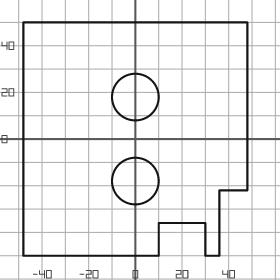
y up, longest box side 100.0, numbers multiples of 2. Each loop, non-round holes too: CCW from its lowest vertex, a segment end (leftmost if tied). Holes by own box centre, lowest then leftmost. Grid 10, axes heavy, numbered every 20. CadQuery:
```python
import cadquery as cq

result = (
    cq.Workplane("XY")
    .moveTo(-48.0, -50.0)
    .lineTo(10.0, -50.0)
    .lineTo(10.0, -36.0)
    .lineTo(30.0, -36.0)
    .lineTo(30.0, -50.0)
    .lineTo(36.0, -50.0)
    .lineTo(36.0, -22.0)
    .lineTo(48.0, -22.0)
    .lineTo(48.0, 50.0)
    .lineTo(-48.0, 50.0)
    .close()
    .moveTo(0.0, -18.0)
    .circle(10.0)
    .moveTo(0.0, 18.0)
    .circle(10.0)
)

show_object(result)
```